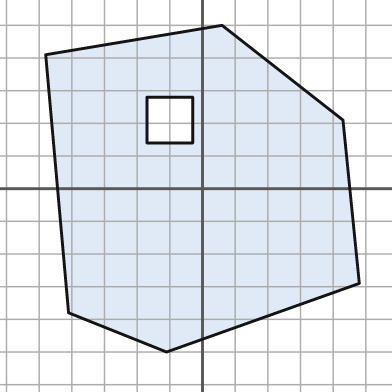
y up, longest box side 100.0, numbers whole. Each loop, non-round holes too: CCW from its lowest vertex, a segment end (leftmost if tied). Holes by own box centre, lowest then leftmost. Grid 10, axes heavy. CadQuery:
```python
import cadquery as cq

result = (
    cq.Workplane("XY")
    .moveTo(-11.0, -50.0)
    .lineTo(48.0, -29.0)
    .lineTo(43.0, 21.0)
    .lineTo(6.0, 50.0)
    .lineTo(-48.0, 41.0)
    .lineTo(-41.0, -38.0)
    .close()
    .moveTo(-17.0, 14.0)
    .lineTo(-3.0, 14.0)
    .lineTo(-3.0, 28.0)
    .lineTo(-17.0, 28.0)
    .close()
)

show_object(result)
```